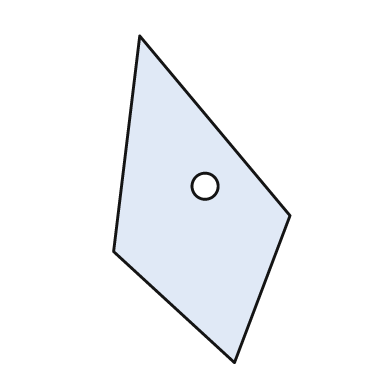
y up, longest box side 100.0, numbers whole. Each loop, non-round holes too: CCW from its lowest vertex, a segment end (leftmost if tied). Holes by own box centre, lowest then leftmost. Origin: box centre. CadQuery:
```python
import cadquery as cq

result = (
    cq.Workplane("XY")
    .moveTo(10.0, -50.0)
    .lineTo(27.0, -5.0)
    .lineTo(-19.0, 50.0)
    .lineTo(-27.0, -16.0)
    .close()
    .moveTo(1.0, 4.0)
    .circle(4.0)
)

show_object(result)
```